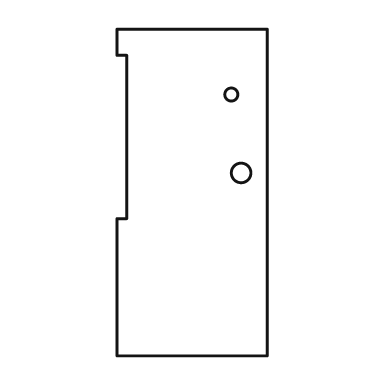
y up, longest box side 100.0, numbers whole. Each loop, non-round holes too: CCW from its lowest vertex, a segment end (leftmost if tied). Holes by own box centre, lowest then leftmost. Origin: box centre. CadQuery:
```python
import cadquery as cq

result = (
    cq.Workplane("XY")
    .moveTo(-23.0, -50.0)
    .lineTo(23.0, -50.0)
    .lineTo(23.0, 50.0)
    .lineTo(-23.0, 50.0)
    .lineTo(-23.0, 42.0)
    .lineTo(-20.0, 42.0)
    .lineTo(-20.0, -8.0)
    .lineTo(-23.0, -8.0)
    .close()
    .moveTo(15.0, 6.0)
    .circle(3.0)
    .moveTo(12.0, 30.0)
    .circle(2.0)
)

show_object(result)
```